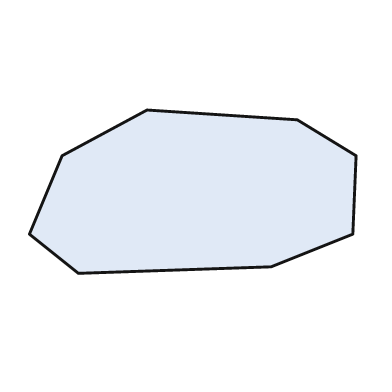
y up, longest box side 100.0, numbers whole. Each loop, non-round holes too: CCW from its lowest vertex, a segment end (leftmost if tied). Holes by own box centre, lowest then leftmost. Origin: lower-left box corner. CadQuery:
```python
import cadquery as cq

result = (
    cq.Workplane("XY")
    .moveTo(15.0, 0.0)
    .lineTo(74.0, 2.0)
    .lineTo(99.0, 12.0)
    .lineTo(100.0, 36.0)
    .lineTo(82.0, 47.0)
    .lineTo(36.0, 50.0)
    .lineTo(10.0, 36.0)
    .lineTo(0.0, 12.0)
    .close()
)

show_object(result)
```